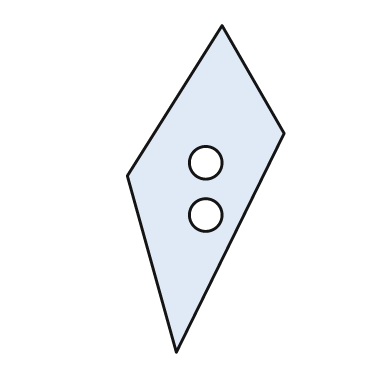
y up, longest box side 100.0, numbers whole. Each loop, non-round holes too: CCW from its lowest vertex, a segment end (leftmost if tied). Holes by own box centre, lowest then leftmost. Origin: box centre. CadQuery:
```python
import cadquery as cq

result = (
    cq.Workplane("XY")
    .moveTo(-9.0, -50.0)
    .lineTo(24.0, 17.0)
    .lineTo(5.0, 50.0)
    .lineTo(-24.0, 4.0)
    .close()
    .moveTo(0.0, -8.0)
    .circle(5.0)
    .moveTo(0.0, 8.0)
    .circle(5.0)
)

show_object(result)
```